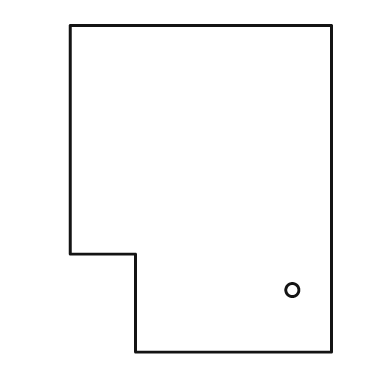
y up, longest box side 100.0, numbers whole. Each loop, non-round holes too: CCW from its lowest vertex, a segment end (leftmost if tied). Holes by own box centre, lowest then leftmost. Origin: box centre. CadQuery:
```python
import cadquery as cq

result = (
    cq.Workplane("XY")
    .moveTo(-20.0, -50.0)
    .lineTo(40.0, -50.0)
    .lineTo(40.0, 50.0)
    .lineTo(-40.0, 50.0)
    .lineTo(-40.0, -20.0)
    .lineTo(-20.0, -20.0)
    .close()
    .moveTo(28.0, -31.0)
    .circle(2.0)
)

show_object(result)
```